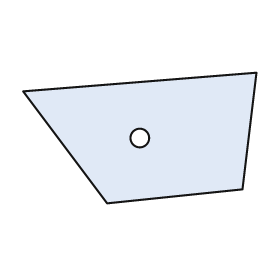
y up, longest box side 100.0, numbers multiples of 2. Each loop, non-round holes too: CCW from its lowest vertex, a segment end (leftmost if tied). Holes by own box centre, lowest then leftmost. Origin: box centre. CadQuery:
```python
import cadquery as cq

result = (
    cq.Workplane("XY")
    .moveTo(-14.0, -28.0)
    .lineTo(44.0, -22.0)
    .lineTo(50.0, 28.0)
    .lineTo(-50.0, 20.0)
    .close()
    .moveTo(0.0, 0.0)
    .circle(4.0)
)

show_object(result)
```